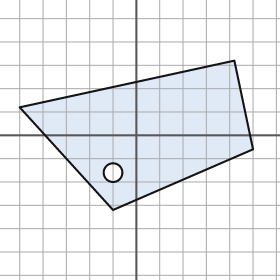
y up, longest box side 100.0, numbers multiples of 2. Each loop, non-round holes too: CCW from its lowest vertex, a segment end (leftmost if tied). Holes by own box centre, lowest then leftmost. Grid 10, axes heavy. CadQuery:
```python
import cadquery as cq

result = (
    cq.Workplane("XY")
    .moveTo(-10.0, -32.0)
    .lineTo(50.0, -6.0)
    .lineTo(42.0, 32.0)
    .lineTo(-50.0, 12.0)
    .close()
    .moveTo(-10.0, -16.0)
    .circle(4.0)
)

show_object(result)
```